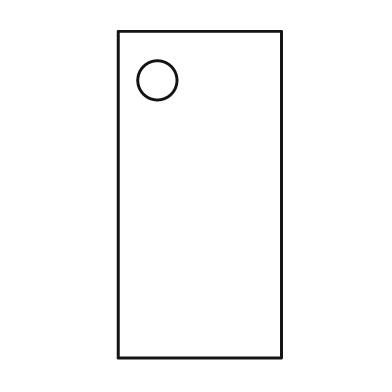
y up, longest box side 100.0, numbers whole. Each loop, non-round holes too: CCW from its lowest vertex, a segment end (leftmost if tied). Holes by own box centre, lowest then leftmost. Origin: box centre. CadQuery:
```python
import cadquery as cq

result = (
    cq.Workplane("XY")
    .moveTo(-25.0, -50.0)
    .lineTo(25.0, -50.0)
    .lineTo(25.0, 50.0)
    .lineTo(-25.0, 50.0)
    .close()
    .moveTo(-13.0, 35.0)
    .circle(6.0)
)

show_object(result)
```